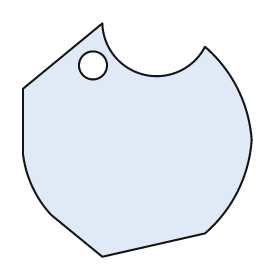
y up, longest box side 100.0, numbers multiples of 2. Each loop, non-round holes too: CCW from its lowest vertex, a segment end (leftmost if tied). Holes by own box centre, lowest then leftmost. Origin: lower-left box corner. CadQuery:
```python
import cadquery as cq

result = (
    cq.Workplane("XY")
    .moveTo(34.0, 0.0)
    .lineTo(78.0, 10.0)
    .threePointArc((92.0, 28.0), (98.0, 50.0))
    .threePointArc((92.0, 72.0), (78.0, 90.0))
    .threePointArc((52.0, 78.0), (34.0, 100.0))
    .lineTo(0.0, 72.0)
    .lineTo(0.0, 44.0)
    .threePointArc((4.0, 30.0), (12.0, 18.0))
    .close()
    .moveTo(30.0, 82.0)
    .circle(6.0)
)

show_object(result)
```